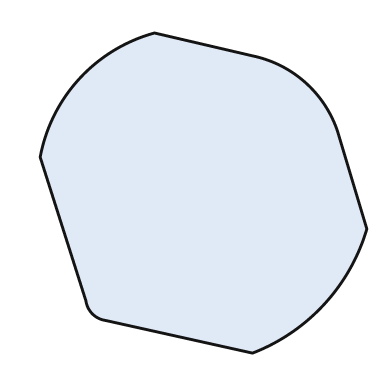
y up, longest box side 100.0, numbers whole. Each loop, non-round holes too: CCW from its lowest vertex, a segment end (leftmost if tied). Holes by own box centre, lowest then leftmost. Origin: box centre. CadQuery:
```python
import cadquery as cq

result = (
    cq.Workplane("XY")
    .moveTo(15.0, -49.0)
    .threePointArc((37.0, -34.0), (50.0, -11.0))
    .lineTo(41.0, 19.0)
    .threePointArc((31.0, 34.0), (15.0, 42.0))
    .lineTo(-15.0, 49.0)
    .threePointArc((-38.0, 35.0), (-50.0, 11.0))
    .lineTo(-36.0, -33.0)
    .threePointArc((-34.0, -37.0), (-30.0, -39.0))
    .close()
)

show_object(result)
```